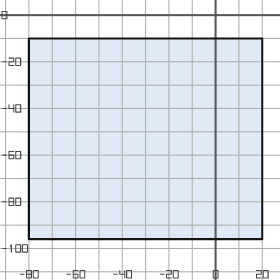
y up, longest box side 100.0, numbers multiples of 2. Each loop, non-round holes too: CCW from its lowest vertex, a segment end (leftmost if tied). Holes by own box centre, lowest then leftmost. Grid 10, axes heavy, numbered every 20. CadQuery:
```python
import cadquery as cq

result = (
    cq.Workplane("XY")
    .moveTo(-80.0, -96.0)
    .lineTo(20.0, -96.0)
    .lineTo(20.0, -10.0)
    .lineTo(-80.0, -10.0)
    .close()
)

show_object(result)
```